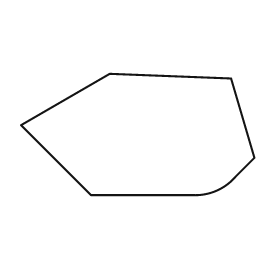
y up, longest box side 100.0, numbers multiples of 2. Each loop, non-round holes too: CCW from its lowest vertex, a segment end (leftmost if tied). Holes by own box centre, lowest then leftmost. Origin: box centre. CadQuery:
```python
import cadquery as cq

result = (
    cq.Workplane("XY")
    .moveTo(-20.0, -26.0)
    .lineTo(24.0, -26.0)
    .threePointArc((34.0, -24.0), (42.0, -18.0))
    .lineTo(50.0, -10.0)
    .lineTo(40.0, 24.0)
    .lineTo(-12.0, 26.0)
    .lineTo(-50.0, 4.0)
    .close()
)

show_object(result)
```